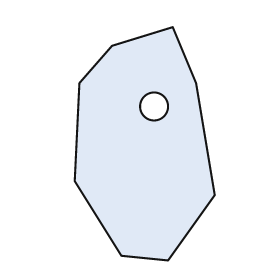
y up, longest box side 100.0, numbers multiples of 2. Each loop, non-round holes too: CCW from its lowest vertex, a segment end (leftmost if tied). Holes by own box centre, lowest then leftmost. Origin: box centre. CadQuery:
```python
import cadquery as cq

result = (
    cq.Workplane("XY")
    .moveTo(10.0, -50.0)
    .lineTo(30.0, -22.0)
    .lineTo(22.0, 26.0)
    .lineTo(12.0, 50.0)
    .lineTo(-14.0, 42.0)
    .lineTo(-28.0, 26.0)
    .lineTo(-30.0, -16.0)
    .lineTo(-10.0, -48.0)
    .close()
    .moveTo(4.0, 16.0)
    .circle(6.0)
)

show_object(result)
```